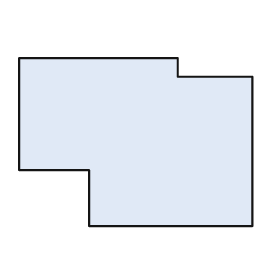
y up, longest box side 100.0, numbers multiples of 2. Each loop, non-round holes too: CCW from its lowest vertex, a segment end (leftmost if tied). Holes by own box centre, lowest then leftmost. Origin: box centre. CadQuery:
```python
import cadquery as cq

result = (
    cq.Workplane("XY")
    .moveTo(-20.0, -36.0)
    .lineTo(50.0, -36.0)
    .lineTo(50.0, 28.0)
    .lineTo(18.0, 28.0)
    .lineTo(18.0, 36.0)
    .lineTo(-50.0, 36.0)
    .lineTo(-50.0, -12.0)
    .lineTo(-20.0, -12.0)
    .close()
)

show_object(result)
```